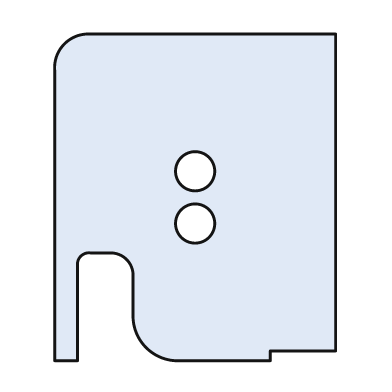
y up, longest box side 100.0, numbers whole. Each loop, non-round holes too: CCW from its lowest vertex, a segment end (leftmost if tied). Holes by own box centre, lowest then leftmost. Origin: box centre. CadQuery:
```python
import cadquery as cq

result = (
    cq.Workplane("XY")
    .moveTo(-43.0, -50.0)
    .lineTo(-36.0, -50.0)
    .lineTo(-36.0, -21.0)
    .threePointArc((-35.0, -18.0), (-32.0, -17.0))
    .lineTo(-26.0, -17.0)
    .threePointArc((-21.0, -19.0), (-19.0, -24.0))
    .lineTo(-19.0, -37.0)
    .threePointArc((-15.0, -46.0), (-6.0, -50.0))
    .lineTo(23.0, -50.0)
    .lineTo(23.0, -47.0)
    .lineTo(43.0, -47.0)
    .lineTo(43.0, 50.0)
    .lineTo(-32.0, 50.0)
    .threePointArc((-40.0, 47.0), (-43.0, 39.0))
    .close()
    .moveTo(0.0, -8.0)
    .circle(6.0)
    .moveTo(0.0, 8.0)
    .circle(6.0)
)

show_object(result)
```